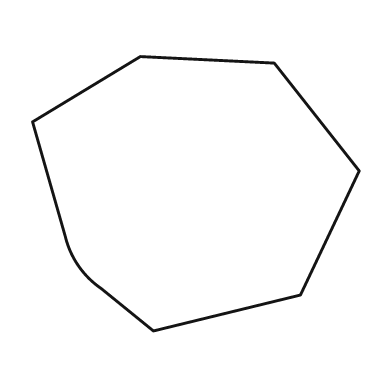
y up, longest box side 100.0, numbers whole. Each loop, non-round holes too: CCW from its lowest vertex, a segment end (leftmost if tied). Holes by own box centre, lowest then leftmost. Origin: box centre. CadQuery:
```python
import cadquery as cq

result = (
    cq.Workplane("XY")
    .moveTo(-13.0, -42.0)
    .lineTo(32.0, -31.0)
    .lineTo(50.0, 7.0)
    .lineTo(24.0, 40.0)
    .lineTo(-17.0, 42.0)
    .lineTo(-50.0, 22.0)
    .lineTo(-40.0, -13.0)
    .threePointArc((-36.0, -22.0), (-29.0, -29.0))
    .close()
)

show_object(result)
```